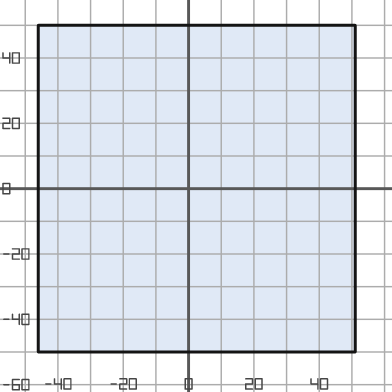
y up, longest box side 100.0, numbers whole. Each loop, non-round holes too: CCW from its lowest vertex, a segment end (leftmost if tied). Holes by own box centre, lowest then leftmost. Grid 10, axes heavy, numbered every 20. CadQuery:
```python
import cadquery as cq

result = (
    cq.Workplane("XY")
    .moveTo(-46.0, -50.0)
    .lineTo(51.0, -50.0)
    .lineTo(51.0, 50.0)
    .lineTo(-46.0, 50.0)
    .close()
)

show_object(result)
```